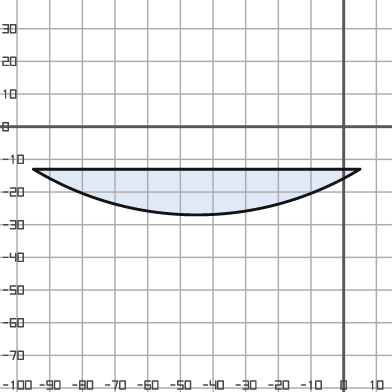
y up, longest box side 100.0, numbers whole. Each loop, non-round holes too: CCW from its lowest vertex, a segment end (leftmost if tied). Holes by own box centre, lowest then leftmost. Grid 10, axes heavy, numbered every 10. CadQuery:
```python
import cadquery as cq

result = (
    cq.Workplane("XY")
    .moveTo(-95.0, -13.0)
    .threePointArc((-45.0, -27.0), (5.0, -13.0))
    .close()
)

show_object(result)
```